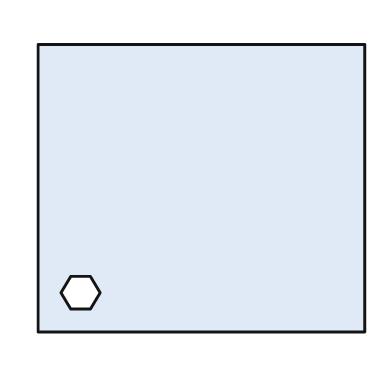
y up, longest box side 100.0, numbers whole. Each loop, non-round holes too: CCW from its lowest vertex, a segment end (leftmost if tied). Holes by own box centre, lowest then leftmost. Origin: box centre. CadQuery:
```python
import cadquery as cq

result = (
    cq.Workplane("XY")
    .moveTo(-50.0, -44.0)
    .lineTo(50.0, -44.0)
    .lineTo(50.0, 44.0)
    .lineTo(-50.0, 44.0)
    .close()
    .moveTo(-40.0, -37.0)
    .lineTo(-34.0, -37.0)
    .lineTo(-31.0, -32.0)
    .lineTo(-34.0, -27.0)
    .lineTo(-40.0, -27.0)
    .lineTo(-43.0, -32.0)
    .close()
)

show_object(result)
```